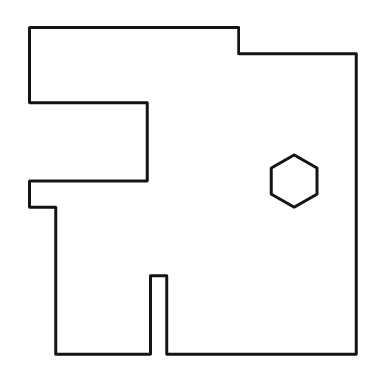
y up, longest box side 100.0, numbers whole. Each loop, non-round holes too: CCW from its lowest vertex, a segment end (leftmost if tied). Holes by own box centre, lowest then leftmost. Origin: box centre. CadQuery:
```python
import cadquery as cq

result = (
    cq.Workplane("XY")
    .moveTo(-42.0, -50.0)
    .lineTo(-13.0, -50.0)
    .lineTo(-13.0, -26.0)
    .lineTo(-8.0, -26.0)
    .lineTo(-8.0, -50.0)
    .lineTo(50.0, -50.0)
    .lineTo(50.0, 42.0)
    .lineTo(14.0, 42.0)
    .lineTo(14.0, 50.0)
    .lineTo(-50.0, 50.0)
    .lineTo(-50.0, 27.0)
    .lineTo(-14.0, 27.0)
    .lineTo(-14.0, 3.0)
    .lineTo(-50.0, 3.0)
    .lineTo(-50.0, -5.0)
    .lineTo(-42.0, -5.0)
    .close()
    .moveTo(31.0, -5.0)
    .lineTo(38.0, -1.0)
    .lineTo(38.0, 7.0)
    .lineTo(31.0, 11.0)
    .lineTo(24.0, 7.0)
    .lineTo(24.0, -1.0)
    .close()
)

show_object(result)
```